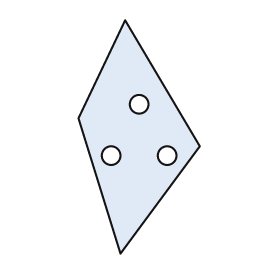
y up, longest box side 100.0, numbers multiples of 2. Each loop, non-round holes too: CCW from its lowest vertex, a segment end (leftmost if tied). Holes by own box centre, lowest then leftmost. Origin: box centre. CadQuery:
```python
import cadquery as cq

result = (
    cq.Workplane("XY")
    .moveTo(-8.0, -50.0)
    .lineTo(26.0, -4.0)
    .lineTo(-6.0, 50.0)
    .lineTo(-26.0, 8.0)
    .close()
    .moveTo(-12.0, -8.0)
    .circle(4.0)
    .moveTo(12.0, -8.0)
    .circle(4.0)
    .moveTo(0.0, 14.0)
    .circle(4.0)
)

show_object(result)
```